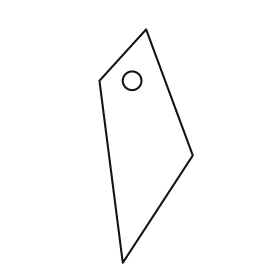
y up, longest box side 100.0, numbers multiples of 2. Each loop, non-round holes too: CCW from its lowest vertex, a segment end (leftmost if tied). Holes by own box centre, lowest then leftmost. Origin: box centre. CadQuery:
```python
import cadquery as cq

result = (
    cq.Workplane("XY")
    .moveTo(-10.0, -50.0)
    .lineTo(20.0, -4.0)
    .lineTo(0.0, 50.0)
    .lineTo(-20.0, 28.0)
    .close()
    .moveTo(-6.0, 28.0)
    .circle(4.0)
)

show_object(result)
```